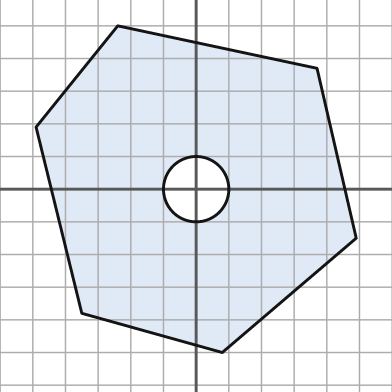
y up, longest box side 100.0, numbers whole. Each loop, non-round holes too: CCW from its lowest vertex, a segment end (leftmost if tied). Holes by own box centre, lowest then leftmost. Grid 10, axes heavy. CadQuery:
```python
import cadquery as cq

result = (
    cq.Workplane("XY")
    .moveTo(8.0, -50.0)
    .lineTo(49.0, -15.0)
    .lineTo(37.0, 37.0)
    .lineTo(-24.0, 50.0)
    .lineTo(-49.0, 19.0)
    .lineTo(-35.0, -38.0)
    .close()
    .moveTo(0.0, 0.0)
    .circle(10.0)
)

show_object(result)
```